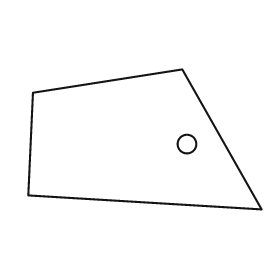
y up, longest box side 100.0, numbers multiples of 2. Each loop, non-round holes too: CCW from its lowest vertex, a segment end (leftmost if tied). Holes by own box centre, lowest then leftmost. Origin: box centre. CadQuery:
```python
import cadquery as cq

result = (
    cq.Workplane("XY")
    .moveTo(50.0, -30.0)
    .lineTo(16.0, 30.0)
    .lineTo(-48.0, 20.0)
    .lineTo(-50.0, -24.0)
    .close()
    .moveTo(18.0, -2.0)
    .circle(4.0)
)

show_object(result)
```